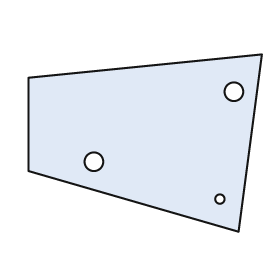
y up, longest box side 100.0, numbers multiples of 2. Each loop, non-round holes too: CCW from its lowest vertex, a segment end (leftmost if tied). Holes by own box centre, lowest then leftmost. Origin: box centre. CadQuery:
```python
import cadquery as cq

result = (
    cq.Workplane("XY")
    .moveTo(40.0, -38.0)
    .lineTo(50.0, 38.0)
    .lineTo(-50.0, 28.0)
    .lineTo(-50.0, -12.0)
    .close()
    .moveTo(32.0, -24.0)
    .circle(2.0)
    .moveTo(-22.0, -8.0)
    .circle(4.0)
    .moveTo(38.0, 22.0)
    .circle(4.0)
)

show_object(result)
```